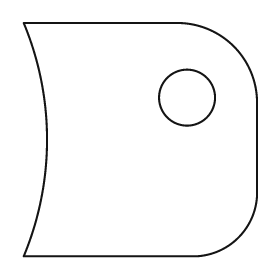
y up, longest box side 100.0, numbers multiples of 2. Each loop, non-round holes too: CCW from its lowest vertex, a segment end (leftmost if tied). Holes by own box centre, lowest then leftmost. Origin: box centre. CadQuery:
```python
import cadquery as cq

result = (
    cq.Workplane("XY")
    .moveTo(-50.0, -50.0)
    .lineTo(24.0, -50.0)
    .threePointArc((42.0, -42.0), (50.0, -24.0))
    .lineTo(50.0, 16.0)
    .threePointArc((40.0, 40.0), (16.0, 50.0))
    .lineTo(-50.0, 50.0)
    .threePointArc((-40.0, 0.0), (-50.0, -50.0))
    .close()
    .moveTo(20.0, 18.0)
    .circle(12.0)
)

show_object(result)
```